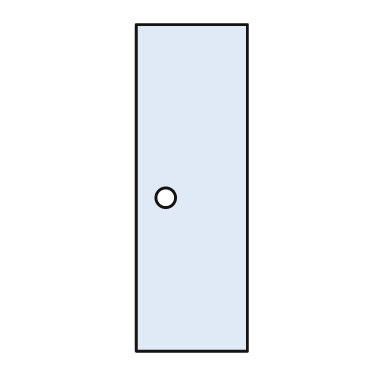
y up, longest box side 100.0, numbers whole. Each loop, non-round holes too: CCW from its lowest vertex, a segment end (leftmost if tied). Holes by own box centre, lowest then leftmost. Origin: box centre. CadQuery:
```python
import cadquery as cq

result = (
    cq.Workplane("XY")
    .moveTo(-17.0, -50.0)
    .lineTo(17.0, -50.0)
    .lineTo(17.0, 50.0)
    .lineTo(-17.0, 50.0)
    .close()
    .moveTo(-8.0, -3.0)
    .circle(3.0)
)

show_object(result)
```